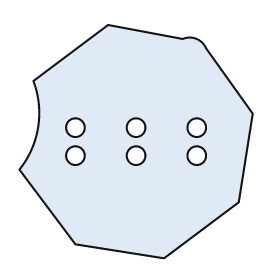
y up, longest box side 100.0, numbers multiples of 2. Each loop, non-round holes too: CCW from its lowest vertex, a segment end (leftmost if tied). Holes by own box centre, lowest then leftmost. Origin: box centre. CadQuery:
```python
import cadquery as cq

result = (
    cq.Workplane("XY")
    .moveTo(12.0, -50.0)
    .lineTo(44.0, -26.0)
    .lineTo(50.0, 12.0)
    .lineTo(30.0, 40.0)
    .threePointArc((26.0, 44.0), (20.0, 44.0))
    .lineTo(-12.0, 50.0)
    .lineTo(-44.0, 26.0)
    .threePointArc((-42.0, 6.0), (-50.0, -12.0))
    .lineTo(-26.0, -44.0)
    .close()
    .moveTo(-26.0, -6.0)
    .circle(4.0)
    .moveTo(0.0, -6.0)
    .circle(4.0)
    .moveTo(26.0, -6.0)
    .circle(4.0)
    .moveTo(-26.0, 6.0)
    .circle(4.0)
    .moveTo(0.0, 6.0)
    .circle(4.0)
    .moveTo(26.0, 6.0)
    .circle(4.0)
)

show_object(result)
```